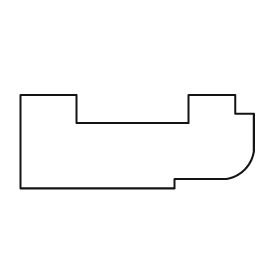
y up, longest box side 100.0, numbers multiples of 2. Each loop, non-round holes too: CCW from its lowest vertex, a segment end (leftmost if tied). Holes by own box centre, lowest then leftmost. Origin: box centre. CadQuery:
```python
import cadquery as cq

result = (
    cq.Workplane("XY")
    .moveTo(-50.0, -20.0)
    .lineTo(16.0, -20.0)
    .lineTo(16.0, -16.0)
    .lineTo(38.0, -16.0)
    .threePointArc((46.0, -12.0), (50.0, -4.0))
    .lineTo(50.0, 12.0)
    .lineTo(42.0, 12.0)
    .lineTo(42.0, 20.0)
    .lineTo(22.0, 20.0)
    .lineTo(22.0, 8.0)
    .lineTo(-26.0, 8.0)
    .lineTo(-26.0, 20.0)
    .lineTo(-50.0, 20.0)
    .close()
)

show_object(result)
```